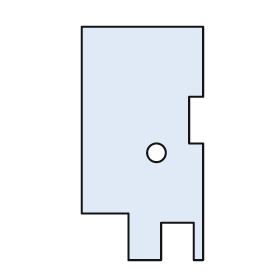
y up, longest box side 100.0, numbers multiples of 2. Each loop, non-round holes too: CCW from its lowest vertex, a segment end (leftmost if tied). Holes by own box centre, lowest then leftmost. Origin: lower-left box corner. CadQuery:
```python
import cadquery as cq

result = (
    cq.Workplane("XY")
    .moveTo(20.0, 0.0)
    .lineTo(34.0, 0.0)
    .lineTo(34.0, 16.0)
    .lineTo(48.0, 16.0)
    .lineTo(48.0, 0.0)
    .lineTo(52.0, 0.0)
    .lineTo(52.0, 50.0)
    .lineTo(46.0, 50.0)
    .lineTo(46.0, 70.0)
    .lineTo(52.0, 70.0)
    .lineTo(52.0, 100.0)
    .lineTo(0.0, 100.0)
    .lineTo(0.0, 20.0)
    .lineTo(20.0, 20.0)
    .close()
    .moveTo(32.0, 46.0)
    .circle(4.0)
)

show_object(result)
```